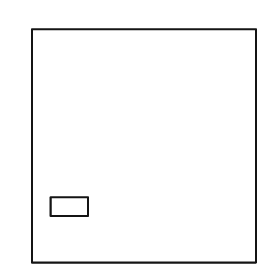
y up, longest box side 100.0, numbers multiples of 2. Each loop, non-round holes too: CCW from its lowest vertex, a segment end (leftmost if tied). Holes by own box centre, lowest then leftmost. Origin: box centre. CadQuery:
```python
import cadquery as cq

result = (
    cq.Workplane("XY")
    .moveTo(-48.0, -50.0)
    .lineTo(48.0, -50.0)
    .lineTo(48.0, 50.0)
    .lineTo(-48.0, 50.0)
    .close()
    .moveTo(-40.0, -30.0)
    .lineTo(-24.0, -30.0)
    .lineTo(-24.0, -22.0)
    .lineTo(-40.0, -22.0)
    .close()
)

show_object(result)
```